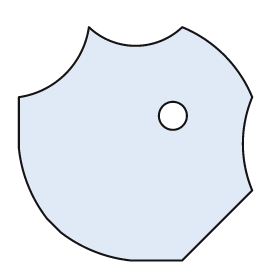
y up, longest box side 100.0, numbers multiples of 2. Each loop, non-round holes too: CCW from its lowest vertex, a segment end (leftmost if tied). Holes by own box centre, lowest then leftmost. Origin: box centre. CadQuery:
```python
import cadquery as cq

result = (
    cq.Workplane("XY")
    .moveTo(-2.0, -50.0)
    .lineTo(20.0, -50.0)
    .lineTo(50.0, -20.0)
    .threePointArc((46.0, 0.0), (50.0, 20.0))
    .threePointArc((38.0, 38.0), (20.0, 50.0))
    .threePointArc((0.0, 42.0), (-20.0, 50.0))
    .threePointArc((-30.0, 30.0), (-50.0, 20.0))
    .lineTo(-50.0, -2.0)
    .threePointArc((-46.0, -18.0), (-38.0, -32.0))
    .lineTo(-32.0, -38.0)
    .threePointArc((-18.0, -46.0), (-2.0, -50.0))
    .close()
    .moveTo(16.0, 12.0)
    .circle(6.0)
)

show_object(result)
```